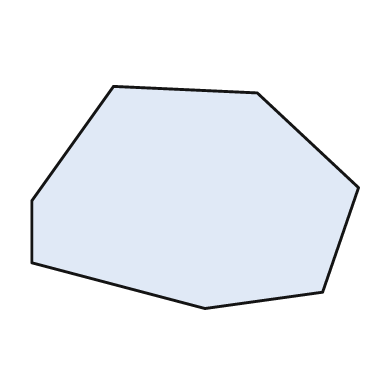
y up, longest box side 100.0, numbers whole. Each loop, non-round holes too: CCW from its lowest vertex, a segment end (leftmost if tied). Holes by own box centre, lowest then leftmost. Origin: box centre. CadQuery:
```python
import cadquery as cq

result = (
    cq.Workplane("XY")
    .moveTo(3.0, -34.0)
    .lineTo(39.0, -29.0)
    .lineTo(50.0, 3.0)
    .lineTo(19.0, 32.0)
    .lineTo(-25.0, 34.0)
    .lineTo(-50.0, -1.0)
    .lineTo(-50.0, -20.0)
    .close()
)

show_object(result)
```